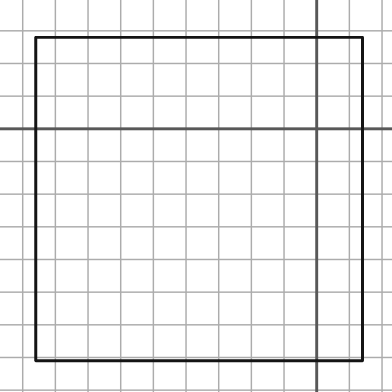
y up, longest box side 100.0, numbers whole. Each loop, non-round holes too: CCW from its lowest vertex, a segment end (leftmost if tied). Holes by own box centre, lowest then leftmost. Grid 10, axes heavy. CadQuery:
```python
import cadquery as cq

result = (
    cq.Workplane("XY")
    .moveTo(-86.0, -71.0)
    .lineTo(14.0, -71.0)
    .lineTo(14.0, 28.0)
    .lineTo(-86.0, 28.0)
    .close()
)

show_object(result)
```